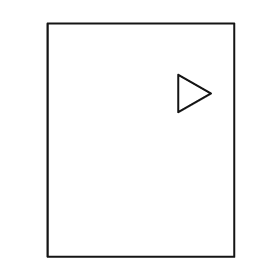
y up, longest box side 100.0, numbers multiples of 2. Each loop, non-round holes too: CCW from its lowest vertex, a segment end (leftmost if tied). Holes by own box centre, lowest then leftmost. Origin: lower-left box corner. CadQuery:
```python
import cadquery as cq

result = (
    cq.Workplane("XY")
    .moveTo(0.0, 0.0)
    .lineTo(80.0, 0.0)
    .lineTo(80.0, 100.0)
    .lineTo(0.0, 100.0)
    .close()
    .moveTo(56.0, 62.0)
    .lineTo(70.0, 70.0)
    .lineTo(56.0, 78.0)
    .close()
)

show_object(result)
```